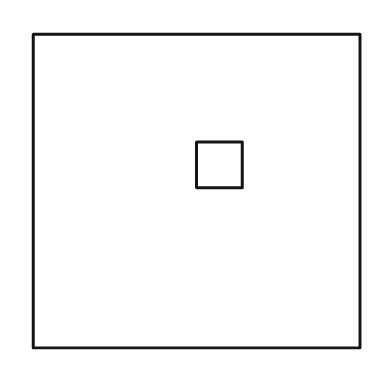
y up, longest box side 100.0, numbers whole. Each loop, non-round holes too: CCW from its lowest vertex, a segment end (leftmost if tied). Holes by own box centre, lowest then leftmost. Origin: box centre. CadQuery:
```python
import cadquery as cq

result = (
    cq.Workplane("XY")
    .moveTo(-50.0, -48.0)
    .lineTo(50.0, -48.0)
    .lineTo(50.0, 48.0)
    .lineTo(-50.0, 48.0)
    .close()
    .moveTo(0.0, 1.0)
    .lineTo(14.0, 1.0)
    .lineTo(14.0, 15.0)
    .lineTo(0.0, 15.0)
    .close()
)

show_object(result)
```